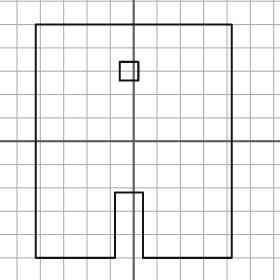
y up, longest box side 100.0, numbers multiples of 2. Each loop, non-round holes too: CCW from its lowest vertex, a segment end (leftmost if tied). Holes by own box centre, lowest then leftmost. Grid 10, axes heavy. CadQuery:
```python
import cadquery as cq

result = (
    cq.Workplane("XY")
    .moveTo(-42.0, -50.0)
    .lineTo(-8.0, -50.0)
    .lineTo(-8.0, -22.0)
    .lineTo(4.0, -22.0)
    .lineTo(4.0, -50.0)
    .lineTo(42.0, -50.0)
    .lineTo(42.0, 50.0)
    .lineTo(-42.0, 50.0)
    .close()
    .moveTo(-6.0, 26.0)
    .lineTo(2.0, 26.0)
    .lineTo(2.0, 34.0)
    .lineTo(-6.0, 34.0)
    .close()
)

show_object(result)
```